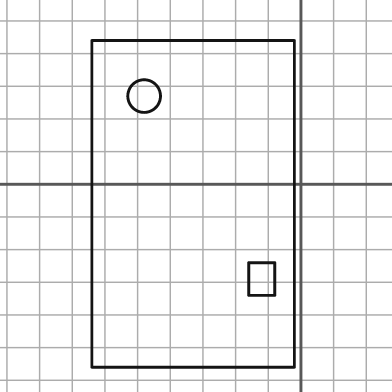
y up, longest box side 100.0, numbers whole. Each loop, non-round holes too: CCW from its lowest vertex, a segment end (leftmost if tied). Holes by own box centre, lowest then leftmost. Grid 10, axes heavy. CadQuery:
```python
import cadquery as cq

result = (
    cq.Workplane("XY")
    .moveTo(-64.0, -56.0)
    .lineTo(-2.0, -56.0)
    .lineTo(-2.0, 44.0)
    .lineTo(-64.0, 44.0)
    .close()
    .moveTo(-16.0, -34.0)
    .lineTo(-8.0, -34.0)
    .lineTo(-8.0, -24.0)
    .lineTo(-16.0, -24.0)
    .close()
    .moveTo(-48.0, 27.0)
    .circle(5.0)
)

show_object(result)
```